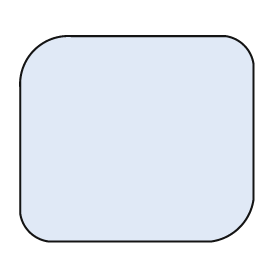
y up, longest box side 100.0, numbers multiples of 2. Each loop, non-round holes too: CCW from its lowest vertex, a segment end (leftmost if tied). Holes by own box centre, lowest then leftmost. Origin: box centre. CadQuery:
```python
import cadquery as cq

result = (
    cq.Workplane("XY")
    .moveTo(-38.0, -44.0)
    .lineTo(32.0, -44.0)
    .threePointArc((44.0, -38.0), (50.0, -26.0))
    .lineTo(50.0, 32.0)
    .threePointArc((46.0, 40.0), (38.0, 44.0))
    .lineTo(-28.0, 44.0)
    .threePointArc((-44.0, 38.0), (-50.0, 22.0))
    .lineTo(-50.0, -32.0)
    .threePointArc((-46.0, -40.0), (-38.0, -44.0))
    .close()
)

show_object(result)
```